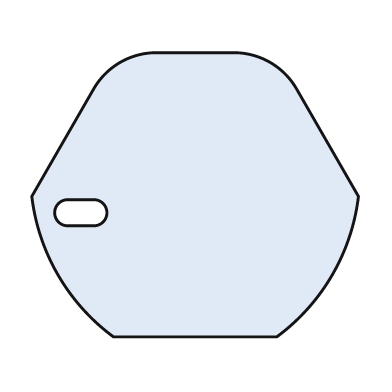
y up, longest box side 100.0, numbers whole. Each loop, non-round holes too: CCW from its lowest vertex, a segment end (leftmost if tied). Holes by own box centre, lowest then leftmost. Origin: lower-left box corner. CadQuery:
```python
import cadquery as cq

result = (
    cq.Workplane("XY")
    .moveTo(25.0, 0.0)
    .lineTo(75.0, 0.0)
    .threePointArc((92.0, 19.0), (100.0, 43.0))
    .lineTo(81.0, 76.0)
    .threePointArc((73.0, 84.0), (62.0, 87.0))
    .lineTo(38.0, 87.0)
    .threePointArc((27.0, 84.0), (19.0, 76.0))
    .lineTo(0.0, 43.0)
    .threePointArc((8.0, 19.0), (25.0, 0.0))
    .close()
    .moveTo(11.0, 34.0)
    .lineTo(19.0, 34.0)
    .threePointArc((23.0, 38.0), (19.0, 42.0))
    .lineTo(11.0, 42.0)
    .threePointArc((7.0, 38.0), (11.0, 34.0))
    .close()
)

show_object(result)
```